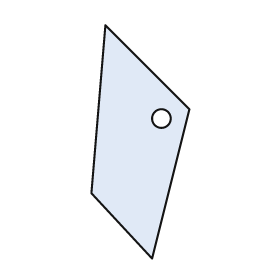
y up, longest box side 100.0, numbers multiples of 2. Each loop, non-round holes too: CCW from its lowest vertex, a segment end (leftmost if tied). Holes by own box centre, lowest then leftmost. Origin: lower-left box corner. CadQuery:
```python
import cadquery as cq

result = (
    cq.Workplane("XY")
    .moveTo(26.0, 0.0)
    .lineTo(42.0, 64.0)
    .lineTo(6.0, 100.0)
    .lineTo(0.0, 28.0)
    .close()
    .moveTo(30.0, 60.0)
    .circle(4.0)
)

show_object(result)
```